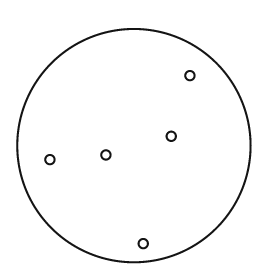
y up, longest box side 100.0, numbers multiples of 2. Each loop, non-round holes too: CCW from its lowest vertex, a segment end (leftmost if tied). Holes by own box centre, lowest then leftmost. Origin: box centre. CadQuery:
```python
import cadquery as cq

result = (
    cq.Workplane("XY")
    .moveTo(0.0, 0.0)
    .circle(50.0)
    .moveTo(4.0, -42.0)
    .circle(2.0)
    .moveTo(-36.0, -6.0)
    .circle(2.0)
    .moveTo(-12.0, -4.0)
    .circle(2.0)
    .moveTo(16.0, 4.0)
    .circle(2.0)
    .moveTo(24.0, 30.0)
    .circle(2.0)
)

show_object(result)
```